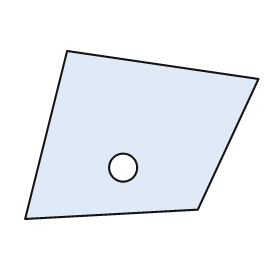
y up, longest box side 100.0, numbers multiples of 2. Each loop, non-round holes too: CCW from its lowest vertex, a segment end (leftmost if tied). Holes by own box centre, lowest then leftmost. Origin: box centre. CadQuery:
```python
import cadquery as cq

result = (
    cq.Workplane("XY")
    .moveTo(-50.0, -36.0)
    .lineTo(24.0, -32.0)
    .lineTo(50.0, 24.0)
    .lineTo(-32.0, 36.0)
    .close()
    .moveTo(-8.0, -14.0)
    .circle(6.0)
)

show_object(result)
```